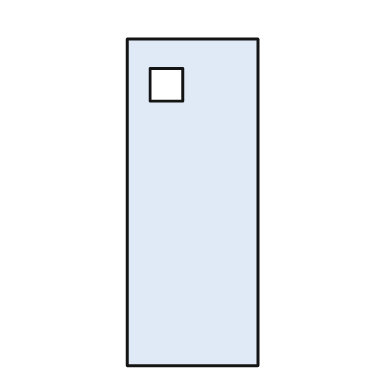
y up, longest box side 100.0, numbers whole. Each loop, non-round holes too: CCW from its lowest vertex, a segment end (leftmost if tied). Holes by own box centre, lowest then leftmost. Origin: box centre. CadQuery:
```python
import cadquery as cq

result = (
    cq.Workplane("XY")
    .moveTo(-20.0, -50.0)
    .lineTo(20.0, -50.0)
    .lineTo(20.0, 50.0)
    .lineTo(-20.0, 50.0)
    .close()
    .moveTo(-13.0, 31.0)
    .lineTo(-3.0, 31.0)
    .lineTo(-3.0, 41.0)
    .lineTo(-13.0, 41.0)
    .close()
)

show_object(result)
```